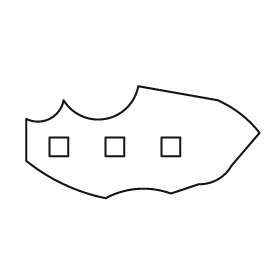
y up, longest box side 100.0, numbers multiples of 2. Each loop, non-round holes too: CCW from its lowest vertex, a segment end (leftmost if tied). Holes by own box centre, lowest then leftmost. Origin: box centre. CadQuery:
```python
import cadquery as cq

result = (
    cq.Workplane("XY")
    .moveTo(-16.0, -24.0)
    .threePointArc((-2.0, -20.0), (12.0, -22.0))
    .lineTo(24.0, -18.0)
    .threePointArc((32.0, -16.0), (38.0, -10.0))
    .lineTo(50.0, 4.0)
    .threePointArc((42.0, 12.0), (32.0, 18.0))
    .lineTo(-2.0, 24.0)
    .threePointArc((-16.0, 10.0), (-34.0, 18.0))
    .threePointArc((-40.0, 10.0), (-50.0, 10.0))
    .lineTo(-50.0, -8.0)
    .threePointArc((-34.0, -18.0), (-16.0, -24.0))
    .close()
    .moveTo(-40.0, -6.0)
    .lineTo(-32.0, -6.0)
    .lineTo(-32.0, 2.0)
    .lineTo(-40.0, 2.0)
    .close()
    .moveTo(-16.0, -6.0)
    .lineTo(-8.0, -6.0)
    .lineTo(-8.0, 2.0)
    .lineTo(-16.0, 2.0)
    .close()
    .moveTo(8.0, -6.0)
    .lineTo(16.0, -6.0)
    .lineTo(16.0, 2.0)
    .lineTo(8.0, 2.0)
    .close()
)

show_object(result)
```